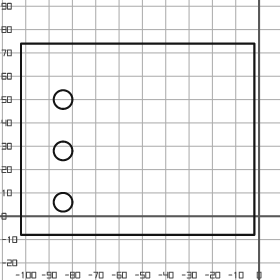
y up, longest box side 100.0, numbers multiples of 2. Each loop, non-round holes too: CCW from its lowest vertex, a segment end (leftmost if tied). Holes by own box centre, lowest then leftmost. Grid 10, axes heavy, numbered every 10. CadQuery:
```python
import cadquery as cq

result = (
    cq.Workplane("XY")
    .moveTo(-102.0, -8.0)
    .lineTo(-2.0, -8.0)
    .lineTo(-2.0, 74.0)
    .lineTo(-102.0, 74.0)
    .close()
    .moveTo(-84.0, 6.0)
    .circle(4.0)
    .moveTo(-84.0, 28.0)
    .circle(4.0)
    .moveTo(-84.0, 50.0)
    .circle(4.0)
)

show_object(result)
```